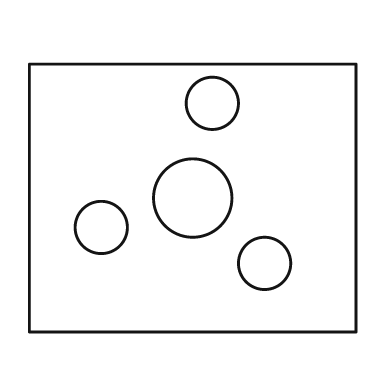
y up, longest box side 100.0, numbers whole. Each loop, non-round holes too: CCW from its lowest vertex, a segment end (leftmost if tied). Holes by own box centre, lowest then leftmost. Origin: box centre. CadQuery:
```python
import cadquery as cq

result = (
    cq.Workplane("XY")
    .moveTo(-50.0, -41.0)
    .lineTo(50.0, -41.0)
    .lineTo(50.0, 41.0)
    .lineTo(-50.0, 41.0)
    .close()
    .moveTo(22.0, -20.0)
    .circle(8.0)
    .moveTo(-28.0, -9.0)
    .circle(8.0)
    .moveTo(0.0, 0.0)
    .circle(12.0)
    .moveTo(6.0, 29.0)
    .circle(8.0)
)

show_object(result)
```